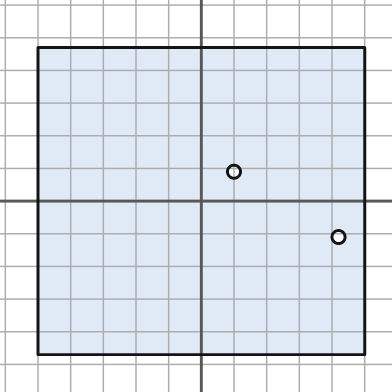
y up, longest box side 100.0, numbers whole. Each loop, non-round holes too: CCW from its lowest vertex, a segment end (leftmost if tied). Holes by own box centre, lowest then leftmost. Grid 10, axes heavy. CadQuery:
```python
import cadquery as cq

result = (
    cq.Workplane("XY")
    .moveTo(-50.0, -47.0)
    .lineTo(50.0, -47.0)
    .lineTo(50.0, 47.0)
    .lineTo(-50.0, 47.0)
    .close()
    .moveTo(42.0, -11.0)
    .circle(2.0)
    .moveTo(10.0, 9.0)
    .circle(2.0)
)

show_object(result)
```